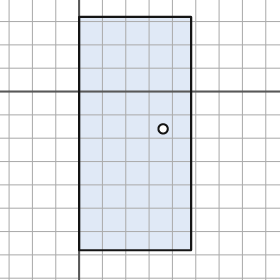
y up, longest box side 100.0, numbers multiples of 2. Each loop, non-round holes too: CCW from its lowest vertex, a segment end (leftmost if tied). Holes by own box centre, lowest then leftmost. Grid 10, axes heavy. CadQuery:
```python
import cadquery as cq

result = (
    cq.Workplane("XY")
    .moveTo(0.0, -68.0)
    .lineTo(48.0, -68.0)
    .lineTo(48.0, 32.0)
    .lineTo(0.0, 32.0)
    .close()
    .moveTo(36.0, -16.0)
    .circle(2.0)
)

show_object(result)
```